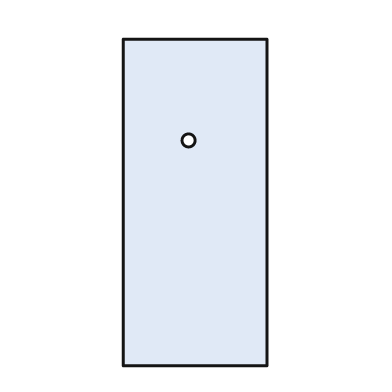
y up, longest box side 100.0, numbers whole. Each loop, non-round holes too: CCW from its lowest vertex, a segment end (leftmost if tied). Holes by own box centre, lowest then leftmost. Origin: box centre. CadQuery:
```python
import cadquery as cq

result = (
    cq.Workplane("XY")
    .moveTo(-22.0, -50.0)
    .lineTo(22.0, -50.0)
    .lineTo(22.0, 50.0)
    .lineTo(-22.0, 50.0)
    .close()
    .moveTo(-2.0, 19.0)
    .circle(2.0)
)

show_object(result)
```